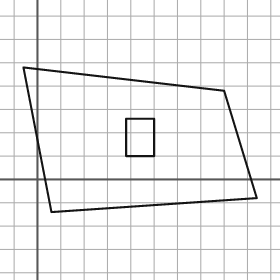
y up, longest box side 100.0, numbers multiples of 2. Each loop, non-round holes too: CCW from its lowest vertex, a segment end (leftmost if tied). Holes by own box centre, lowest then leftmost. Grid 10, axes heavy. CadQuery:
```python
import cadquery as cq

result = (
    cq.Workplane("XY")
    .moveTo(6.0, -14.0)
    .lineTo(94.0, -8.0)
    .lineTo(80.0, 38.0)
    .lineTo(-6.0, 48.0)
    .close()
    .moveTo(38.0, 10.0)
    .lineTo(50.0, 10.0)
    .lineTo(50.0, 26.0)
    .lineTo(38.0, 26.0)
    .close()
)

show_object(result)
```